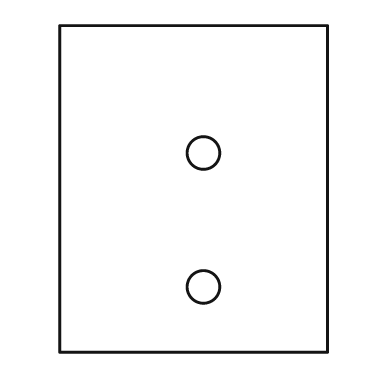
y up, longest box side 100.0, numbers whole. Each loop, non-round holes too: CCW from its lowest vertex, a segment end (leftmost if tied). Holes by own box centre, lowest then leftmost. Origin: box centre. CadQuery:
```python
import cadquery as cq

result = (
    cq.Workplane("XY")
    .moveTo(-41.0, -50.0)
    .lineTo(41.0, -50.0)
    .lineTo(41.0, 50.0)
    .lineTo(-41.0, 50.0)
    .close()
    .moveTo(3.0, -30.0)
    .circle(5.0)
    .moveTo(3.0, 11.0)
    .circle(5.0)
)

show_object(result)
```